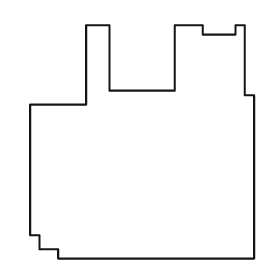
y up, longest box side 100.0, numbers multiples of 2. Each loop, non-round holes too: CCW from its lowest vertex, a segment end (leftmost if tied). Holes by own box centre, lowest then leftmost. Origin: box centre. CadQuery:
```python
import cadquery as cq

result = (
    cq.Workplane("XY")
    .moveTo(-36.0, -50.0)
    .lineTo(48.0, -50.0)
    .lineTo(48.0, 20.0)
    .lineTo(44.0, 20.0)
    .lineTo(44.0, 50.0)
    .lineTo(40.0, 50.0)
    .lineTo(40.0, 46.0)
    .lineTo(26.0, 46.0)
    .lineTo(26.0, 50.0)
    .lineTo(14.0, 50.0)
    .lineTo(14.0, 22.0)
    .lineTo(-14.0, 22.0)
    .lineTo(-14.0, 50.0)
    .lineTo(-24.0, 50.0)
    .lineTo(-24.0, 16.0)
    .lineTo(-48.0, 16.0)
    .lineTo(-48.0, -40.0)
    .lineTo(-44.0, -40.0)
    .lineTo(-44.0, -46.0)
    .lineTo(-36.0, -46.0)
    .close()
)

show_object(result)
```